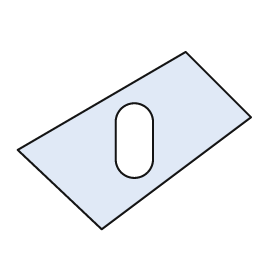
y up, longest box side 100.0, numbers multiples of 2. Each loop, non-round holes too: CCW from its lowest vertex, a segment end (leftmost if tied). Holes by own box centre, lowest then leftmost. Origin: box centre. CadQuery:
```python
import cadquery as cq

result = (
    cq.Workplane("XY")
    .moveTo(-14.0, -38.0)
    .lineTo(50.0, 10.0)
    .lineTo(22.0, 38.0)
    .lineTo(-50.0, -4.0)
    .close()
    .moveTo(-8.0, -8.0)
    .threePointArc((0.0, -16.0), (8.0, -8.0))
    .lineTo(8.0, 8.0)
    .threePointArc((0.0, 16.0), (-8.0, 8.0))
    .close()
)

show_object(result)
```